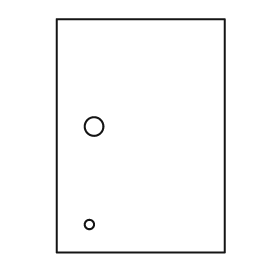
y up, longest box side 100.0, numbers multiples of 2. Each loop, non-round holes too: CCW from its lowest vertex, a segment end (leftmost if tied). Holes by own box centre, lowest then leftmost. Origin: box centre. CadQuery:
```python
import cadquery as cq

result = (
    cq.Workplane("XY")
    .moveTo(-36.0, -50.0)
    .lineTo(36.0, -50.0)
    .lineTo(36.0, 50.0)
    .lineTo(-36.0, 50.0)
    .close()
    .moveTo(-22.0, -38.0)
    .circle(2.0)
    .moveTo(-20.0, 4.0)
    .circle(4.0)
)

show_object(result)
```